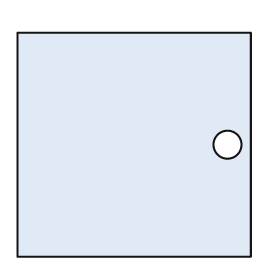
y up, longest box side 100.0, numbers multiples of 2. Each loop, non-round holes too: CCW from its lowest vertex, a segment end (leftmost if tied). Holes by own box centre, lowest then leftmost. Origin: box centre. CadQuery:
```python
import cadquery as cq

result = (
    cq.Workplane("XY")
    .moveTo(-50.0, -48.0)
    .lineTo(50.0, -48.0)
    .lineTo(50.0, 48.0)
    .lineTo(-50.0, 48.0)
    .close()
    .moveTo(40.0, 0.0)
    .circle(6.0)
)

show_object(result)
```